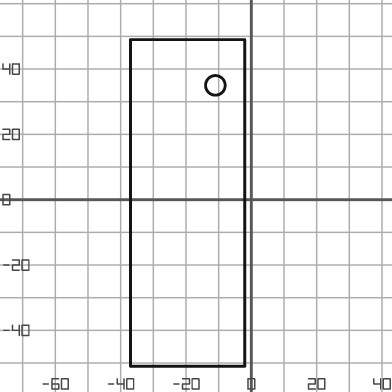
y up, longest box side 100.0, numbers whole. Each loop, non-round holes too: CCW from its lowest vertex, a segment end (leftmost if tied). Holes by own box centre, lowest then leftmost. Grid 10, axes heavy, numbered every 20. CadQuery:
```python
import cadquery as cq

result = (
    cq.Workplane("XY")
    .moveTo(-37.0, -51.0)
    .lineTo(-2.0, -51.0)
    .lineTo(-2.0, 49.0)
    .lineTo(-37.0, 49.0)
    .close()
    .moveTo(-11.0, 35.0)
    .circle(3.0)
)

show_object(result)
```